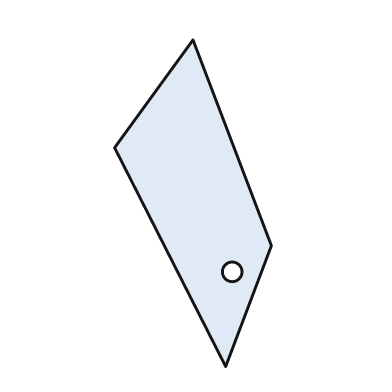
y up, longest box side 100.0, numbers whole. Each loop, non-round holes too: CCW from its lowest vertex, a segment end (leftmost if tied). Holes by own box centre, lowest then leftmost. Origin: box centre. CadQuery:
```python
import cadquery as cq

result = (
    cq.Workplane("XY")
    .moveTo(10.0, -50.0)
    .lineTo(24.0, -13.0)
    .lineTo(0.0, 50.0)
    .lineTo(-24.0, 17.0)
    .close()
    .moveTo(12.0, -21.0)
    .circle(3.0)
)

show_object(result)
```